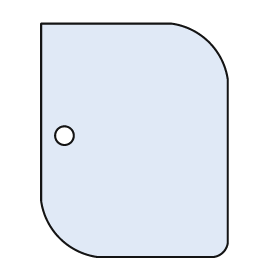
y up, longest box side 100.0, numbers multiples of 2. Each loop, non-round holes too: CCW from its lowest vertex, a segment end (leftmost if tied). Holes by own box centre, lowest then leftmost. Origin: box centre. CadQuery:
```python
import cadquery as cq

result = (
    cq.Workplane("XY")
    .moveTo(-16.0, -50.0)
    .lineTo(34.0, -50.0)
    .threePointArc((38.0, -48.0), (40.0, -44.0))
    .lineTo(40.0, 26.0)
    .threePointArc((32.0, 42.0), (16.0, 50.0))
    .lineTo(-40.0, 50.0)
    .lineTo(-40.0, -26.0)
    .threePointArc((-32.0, -42.0), (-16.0, -50.0))
    .close()
    .moveTo(-30.0, 2.0)
    .circle(4.0)
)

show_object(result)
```